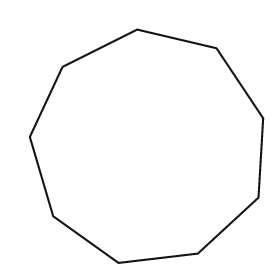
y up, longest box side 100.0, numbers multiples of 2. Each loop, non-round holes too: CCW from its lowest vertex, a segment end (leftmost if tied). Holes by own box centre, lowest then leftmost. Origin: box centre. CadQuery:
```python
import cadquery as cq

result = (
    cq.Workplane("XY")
    .moveTo(-12.0, -50.0)
    .lineTo(22.0, -46.0)
    .lineTo(48.0, -22.0)
    .lineTo(50.0, 12.0)
    .lineTo(30.0, 42.0)
    .lineTo(-4.0, 50.0)
    .lineTo(-36.0, 34.0)
    .lineTo(-50.0, 4.0)
    .lineTo(-40.0, -30.0)
    .close()
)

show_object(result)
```